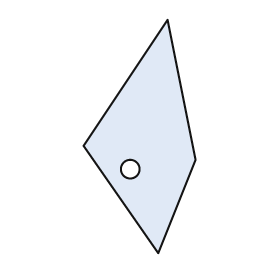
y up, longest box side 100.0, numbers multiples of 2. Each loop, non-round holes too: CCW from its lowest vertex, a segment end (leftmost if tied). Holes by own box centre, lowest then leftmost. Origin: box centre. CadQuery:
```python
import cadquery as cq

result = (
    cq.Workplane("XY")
    .moveTo(8.0, -50.0)
    .lineTo(24.0, -10.0)
    .lineTo(12.0, 50.0)
    .lineTo(-24.0, -4.0)
    .close()
    .moveTo(-4.0, -14.0)
    .circle(4.0)
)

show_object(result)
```